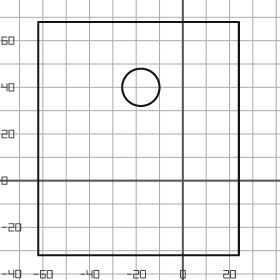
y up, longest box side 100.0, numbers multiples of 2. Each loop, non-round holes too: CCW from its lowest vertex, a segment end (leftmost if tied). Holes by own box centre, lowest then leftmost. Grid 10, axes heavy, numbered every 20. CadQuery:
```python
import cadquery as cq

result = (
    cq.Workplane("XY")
    .moveTo(-62.0, -32.0)
    .lineTo(24.0, -32.0)
    .lineTo(24.0, 68.0)
    .lineTo(-62.0, 68.0)
    .close()
    .moveTo(-18.0, 40.0)
    .circle(8.0)
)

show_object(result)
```